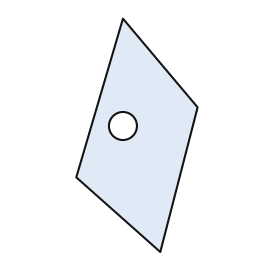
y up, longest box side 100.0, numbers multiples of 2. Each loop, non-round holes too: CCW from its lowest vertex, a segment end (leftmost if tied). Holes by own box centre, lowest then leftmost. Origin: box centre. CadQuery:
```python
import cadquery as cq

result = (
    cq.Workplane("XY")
    .moveTo(10.0, -50.0)
    .lineTo(26.0, 12.0)
    .lineTo(-6.0, 50.0)
    .lineTo(-26.0, -18.0)
    .close()
    .moveTo(-6.0, 4.0)
    .circle(6.0)
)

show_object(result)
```